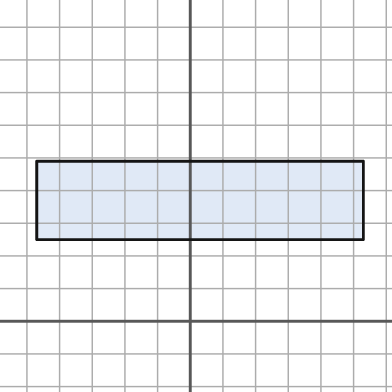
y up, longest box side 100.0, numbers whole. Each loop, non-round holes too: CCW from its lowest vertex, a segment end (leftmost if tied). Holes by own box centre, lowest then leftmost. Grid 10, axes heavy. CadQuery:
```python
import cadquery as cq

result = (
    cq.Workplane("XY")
    .moveTo(-47.0, 25.0)
    .lineTo(53.0, 25.0)
    .lineTo(53.0, 49.0)
    .lineTo(-47.0, 49.0)
    .close()
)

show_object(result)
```